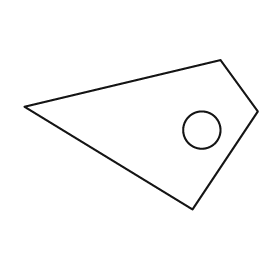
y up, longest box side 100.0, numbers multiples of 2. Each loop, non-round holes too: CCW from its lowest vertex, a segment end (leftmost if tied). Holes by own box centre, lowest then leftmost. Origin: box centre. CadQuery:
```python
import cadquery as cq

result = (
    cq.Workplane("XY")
    .moveTo(22.0, -32.0)
    .lineTo(50.0, 10.0)
    .lineTo(34.0, 32.0)
    .lineTo(-50.0, 12.0)
    .close()
    .moveTo(26.0, 2.0)
    .circle(8.0)
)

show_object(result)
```